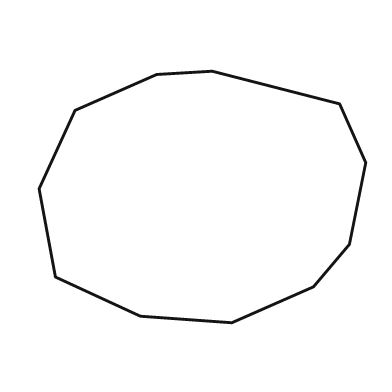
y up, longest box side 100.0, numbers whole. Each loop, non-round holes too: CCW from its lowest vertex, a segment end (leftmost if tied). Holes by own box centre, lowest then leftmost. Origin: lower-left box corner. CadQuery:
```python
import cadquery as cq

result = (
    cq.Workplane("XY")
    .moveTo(59.0, 0.0)
    .lineTo(84.0, 11.0)
    .lineTo(95.0, 24.0)
    .lineTo(100.0, 49.0)
    .lineTo(92.0, 67.0)
    .lineTo(53.0, 77.0)
    .lineTo(36.0, 76.0)
    .lineTo(11.0, 65.0)
    .lineTo(0.0, 41.0)
    .lineTo(5.0, 14.0)
    .lineTo(31.0, 2.0)
    .close()
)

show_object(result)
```